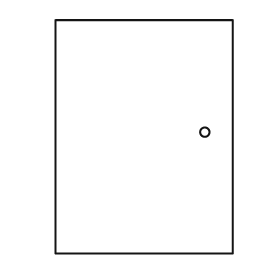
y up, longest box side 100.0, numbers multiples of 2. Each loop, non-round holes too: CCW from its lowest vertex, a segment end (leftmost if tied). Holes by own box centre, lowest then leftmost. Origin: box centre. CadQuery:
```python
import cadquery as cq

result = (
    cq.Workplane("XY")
    .moveTo(-38.0, -50.0)
    .lineTo(38.0, -50.0)
    .lineTo(38.0, 50.0)
    .lineTo(-38.0, 50.0)
    .close()
    .moveTo(26.0, 2.0)
    .circle(2.0)
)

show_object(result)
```